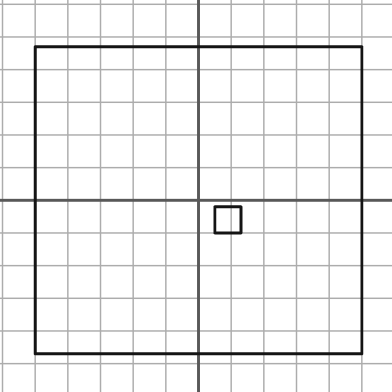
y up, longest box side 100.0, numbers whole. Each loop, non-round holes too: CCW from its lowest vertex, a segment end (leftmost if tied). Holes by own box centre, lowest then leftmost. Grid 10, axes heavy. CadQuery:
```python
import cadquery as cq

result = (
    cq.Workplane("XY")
    .moveTo(-50.0, -47.0)
    .lineTo(50.0, -47.0)
    .lineTo(50.0, 47.0)
    .lineTo(-50.0, 47.0)
    .close()
    .moveTo(5.0, -10.0)
    .lineTo(13.0, -10.0)
    .lineTo(13.0, -2.0)
    .lineTo(5.0, -2.0)
    .close()
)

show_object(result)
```